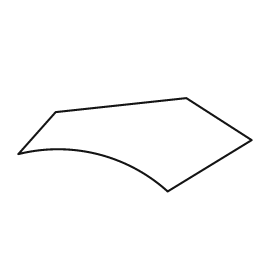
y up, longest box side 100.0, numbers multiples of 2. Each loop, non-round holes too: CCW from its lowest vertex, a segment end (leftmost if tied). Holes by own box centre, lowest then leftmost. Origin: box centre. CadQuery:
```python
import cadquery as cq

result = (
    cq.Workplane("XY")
    .moveTo(14.0, -20.0)
    .lineTo(50.0, 2.0)
    .lineTo(22.0, 20.0)
    .lineTo(-34.0, 14.0)
    .lineTo(-50.0, -4.0)
    .threePointArc((-16.0, -4.0), (14.0, -20.0))
    .close()
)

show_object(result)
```